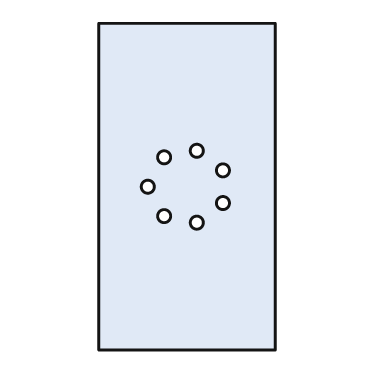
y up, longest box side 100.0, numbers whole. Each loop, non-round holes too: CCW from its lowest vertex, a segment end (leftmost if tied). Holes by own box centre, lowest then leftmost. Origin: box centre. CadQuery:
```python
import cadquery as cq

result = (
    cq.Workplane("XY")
    .moveTo(-27.0, -50.0)
    .lineTo(27.0, -50.0)
    .lineTo(27.0, 50.0)
    .lineTo(-27.0, 50.0)
    .close()
    .moveTo(3.0, -11.0)
    .circle(2.0)
    .moveTo(-7.0, -9.0)
    .circle(2.0)
    .moveTo(11.0, -5.0)
    .circle(2.0)
    .moveTo(-12.0, 0.0)
    .circle(2.0)
    .moveTo(11.0, 5.0)
    .circle(2.0)
    .moveTo(-7.0, 9.0)
    .circle(2.0)
    .moveTo(3.0, 11.0)
    .circle(2.0)
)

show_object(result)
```